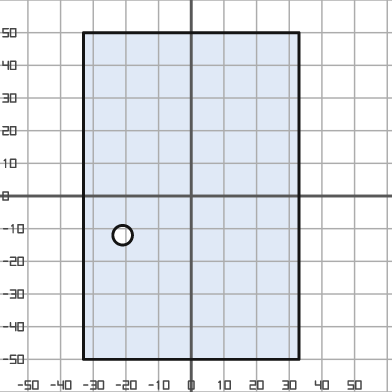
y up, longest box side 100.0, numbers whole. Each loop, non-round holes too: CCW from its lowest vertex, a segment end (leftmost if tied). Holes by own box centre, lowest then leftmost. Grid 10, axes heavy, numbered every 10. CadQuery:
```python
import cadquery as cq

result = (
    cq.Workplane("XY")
    .moveTo(-33.0, -50.0)
    .lineTo(33.0, -50.0)
    .lineTo(33.0, 50.0)
    .lineTo(-33.0, 50.0)
    .close()
    .moveTo(-21.0, -12.0)
    .circle(3.0)
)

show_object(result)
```